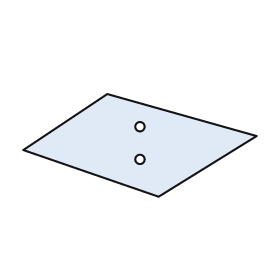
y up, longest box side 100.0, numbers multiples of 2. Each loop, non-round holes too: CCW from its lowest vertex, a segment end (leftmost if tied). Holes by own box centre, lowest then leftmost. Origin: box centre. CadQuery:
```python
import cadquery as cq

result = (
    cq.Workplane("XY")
    .moveTo(8.0, -22.0)
    .lineTo(50.0, 4.0)
    .lineTo(-14.0, 22.0)
    .lineTo(-50.0, -2.0)
    .close()
    .moveTo(0.0, -6.0)
    .circle(2.0)
    .moveTo(0.0, 8.0)
    .circle(2.0)
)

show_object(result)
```